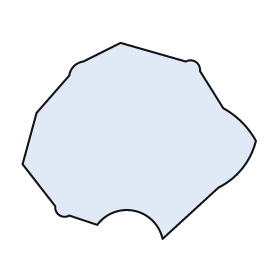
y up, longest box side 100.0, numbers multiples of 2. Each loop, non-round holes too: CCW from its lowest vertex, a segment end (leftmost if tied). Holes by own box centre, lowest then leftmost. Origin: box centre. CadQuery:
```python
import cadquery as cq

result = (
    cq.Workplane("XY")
    .moveTo(10.0, -42.0)
    .lineTo(34.0, -20.0)
    .threePointArc((44.0, -12.0), (50.0, 0.0))
    .threePointArc((44.0, 8.0), (36.0, 14.0))
    .lineTo(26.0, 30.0)
    .threePointArc((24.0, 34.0), (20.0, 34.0))
    .lineTo(-8.0, 42.0)
    .lineTo(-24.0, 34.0)
    .threePointArc((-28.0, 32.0), (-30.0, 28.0))
    .lineTo(-44.0, 12.0)
    .lineTo(-50.0, -10.0)
    .lineTo(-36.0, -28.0)
    .threePointArc((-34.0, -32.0), (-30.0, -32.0))
    .lineTo(-18.0, -36.0)
    .threePointArc((-2.0, -30.0), (10.0, -42.0))
    .close()
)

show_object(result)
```